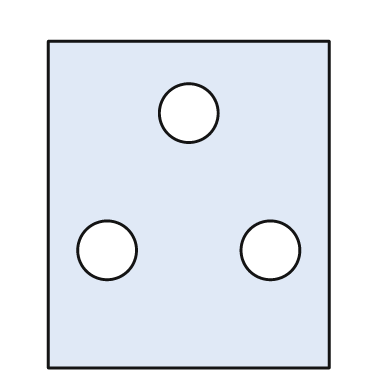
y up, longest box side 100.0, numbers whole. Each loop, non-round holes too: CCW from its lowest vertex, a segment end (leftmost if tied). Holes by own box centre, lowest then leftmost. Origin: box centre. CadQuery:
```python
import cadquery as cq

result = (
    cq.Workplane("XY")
    .moveTo(-43.0, -50.0)
    .lineTo(43.0, -50.0)
    .lineTo(43.0, 50.0)
    .lineTo(-43.0, 50.0)
    .close()
    .moveTo(-25.0, -14.0)
    .circle(9.0)
    .moveTo(25.0, -14.0)
    .circle(9.0)
    .moveTo(0.0, 28.0)
    .circle(9.0)
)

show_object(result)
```